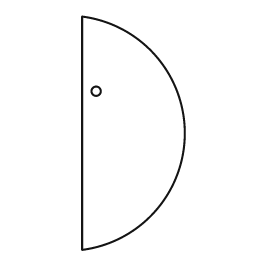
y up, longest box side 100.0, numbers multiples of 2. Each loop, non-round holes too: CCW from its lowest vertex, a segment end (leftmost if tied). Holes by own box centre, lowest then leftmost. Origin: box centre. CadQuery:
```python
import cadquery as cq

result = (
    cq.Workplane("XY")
    .moveTo(-22.0, -50.0)
    .threePointArc((22.0, 0.0), (-22.0, 50.0))
    .close()
    .moveTo(-16.0, 18.0)
    .circle(2.0)
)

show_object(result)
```